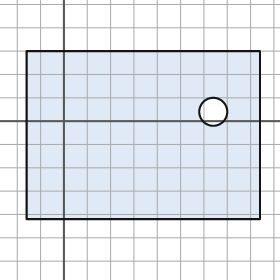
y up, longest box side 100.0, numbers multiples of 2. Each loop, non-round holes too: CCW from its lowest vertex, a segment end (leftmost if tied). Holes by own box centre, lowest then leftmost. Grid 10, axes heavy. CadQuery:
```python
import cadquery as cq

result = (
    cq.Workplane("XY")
    .moveTo(-16.0, -42.0)
    .lineTo(84.0, -42.0)
    .lineTo(84.0, 30.0)
    .lineTo(-16.0, 30.0)
    .close()
    .moveTo(64.0, 4.0)
    .circle(6.0)
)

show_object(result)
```